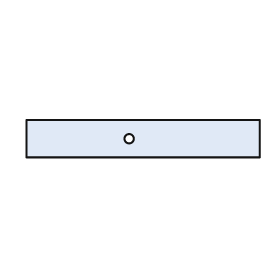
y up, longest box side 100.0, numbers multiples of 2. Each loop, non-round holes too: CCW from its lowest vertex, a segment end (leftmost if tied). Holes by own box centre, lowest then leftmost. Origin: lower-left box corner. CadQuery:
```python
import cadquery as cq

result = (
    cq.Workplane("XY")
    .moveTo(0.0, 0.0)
    .lineTo(100.0, 0.0)
    .lineTo(100.0, 16.0)
    .lineTo(0.0, 16.0)
    .close()
    .moveTo(44.0, 8.0)
    .circle(2.0)
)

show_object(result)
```